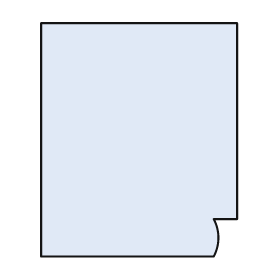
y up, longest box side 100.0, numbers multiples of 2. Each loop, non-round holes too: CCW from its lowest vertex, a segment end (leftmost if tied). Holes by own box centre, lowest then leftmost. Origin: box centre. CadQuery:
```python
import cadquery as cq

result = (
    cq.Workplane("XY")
    .moveTo(-42.0, -50.0)
    .lineTo(32.0, -50.0)
    .threePointArc((34.0, -42.0), (32.0, -34.0))
    .lineTo(42.0, -34.0)
    .lineTo(42.0, 50.0)
    .lineTo(-42.0, 50.0)
    .close()
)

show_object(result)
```